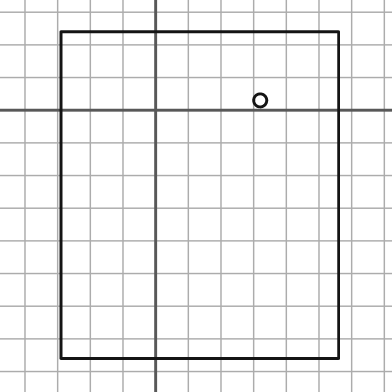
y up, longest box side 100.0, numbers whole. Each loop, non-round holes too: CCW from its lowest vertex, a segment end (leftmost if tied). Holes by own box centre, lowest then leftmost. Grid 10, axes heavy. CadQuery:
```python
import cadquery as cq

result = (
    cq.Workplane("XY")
    .moveTo(-29.0, -76.0)
    .lineTo(56.0, -76.0)
    .lineTo(56.0, 24.0)
    .lineTo(-29.0, 24.0)
    .close()
    .moveTo(32.0, 3.0)
    .circle(2.0)
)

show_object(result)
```